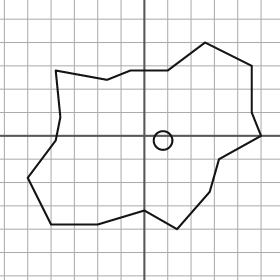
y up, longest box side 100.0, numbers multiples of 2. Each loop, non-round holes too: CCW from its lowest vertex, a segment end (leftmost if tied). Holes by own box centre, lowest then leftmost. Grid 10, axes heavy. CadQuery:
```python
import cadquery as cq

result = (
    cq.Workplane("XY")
    .moveTo(14.0, -40.0)
    .lineTo(28.0, -24.0)
    .lineTo(32.0, -10.0)
    .lineTo(50.0, 0.0)
    .lineTo(46.0, 10.0)
    .lineTo(46.0, 30.0)
    .lineTo(26.0, 40.0)
    .lineTo(10.0, 28.0)
    .lineTo(-6.0, 28.0)
    .lineTo(-16.0, 24.0)
    .lineTo(-38.0, 28.0)
    .lineTo(-36.0, 8.0)
    .lineTo(-38.0, -2.0)
    .lineTo(-50.0, -18.0)
    .lineTo(-40.0, -38.0)
    .lineTo(-20.0, -38.0)
    .lineTo(0.0, -32.0)
    .close()
    .moveTo(8.0, -2.0)
    .circle(4.0)
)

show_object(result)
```